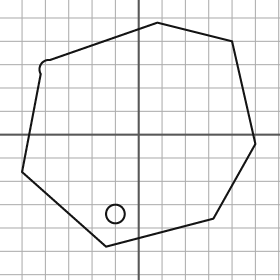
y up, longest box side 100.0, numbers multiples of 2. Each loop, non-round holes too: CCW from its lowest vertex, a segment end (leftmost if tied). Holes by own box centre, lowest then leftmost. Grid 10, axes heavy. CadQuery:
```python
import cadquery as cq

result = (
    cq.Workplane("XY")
    .moveTo(-14.0, -48.0)
    .lineTo(32.0, -36.0)
    .lineTo(50.0, -4.0)
    .lineTo(40.0, 40.0)
    .lineTo(8.0, 48.0)
    .lineTo(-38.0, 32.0)
    .threePointArc((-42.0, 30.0), (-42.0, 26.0))
    .lineTo(-50.0, -16.0)
    .close()
    .moveTo(-10.0, -34.0)
    .circle(4.0)
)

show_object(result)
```